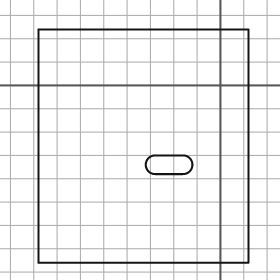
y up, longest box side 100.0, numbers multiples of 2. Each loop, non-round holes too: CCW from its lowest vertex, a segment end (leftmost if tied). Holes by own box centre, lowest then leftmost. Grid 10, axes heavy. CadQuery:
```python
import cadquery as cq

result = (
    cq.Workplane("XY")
    .moveTo(-78.0, -76.0)
    .lineTo(12.0, -76.0)
    .lineTo(12.0, 24.0)
    .lineTo(-78.0, 24.0)
    .close()
    .moveTo(-28.0, -38.0)
    .lineTo(-16.0, -38.0)
    .threePointArc((-12.0, -34.0), (-16.0, -30.0))
    .lineTo(-28.0, -30.0)
    .threePointArc((-32.0, -34.0), (-28.0, -38.0))
    .close()
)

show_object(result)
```